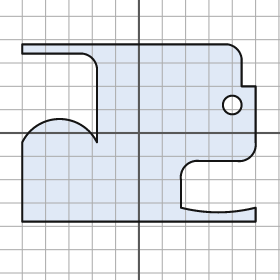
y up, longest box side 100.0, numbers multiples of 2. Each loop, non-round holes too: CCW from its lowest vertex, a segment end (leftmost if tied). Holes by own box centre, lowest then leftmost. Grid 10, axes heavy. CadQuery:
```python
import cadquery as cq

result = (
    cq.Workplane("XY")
    .moveTo(-50.0, -38.0)
    .lineTo(50.0, -38.0)
    .lineTo(50.0, -32.0)
    .threePointArc((34.0, -34.0), (18.0, -32.0))
    .lineTo(18.0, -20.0)
    .threePointArc((20.0, -14.0), (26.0, -12.0))
    .lineTo(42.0, -12.0)
    .threePointArc((48.0, -10.0), (50.0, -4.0))
    .lineTo(50.0, 20.0)
    .lineTo(44.0, 20.0)
    .lineTo(44.0, 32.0)
    .threePointArc((42.0, 36.0), (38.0, 38.0))
    .lineTo(-50.0, 38.0)
    .lineTo(-50.0, 34.0)
    .lineTo(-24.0, 34.0)
    .threePointArc((-20.0, 32.0), (-18.0, 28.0))
    .lineTo(-18.0, -4.0)
    .threePointArc((-34.0, 6.0), (-50.0, -4.0))
    .close()
    .moveTo(40.0, 12.0)
    .circle(4.0)
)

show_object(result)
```